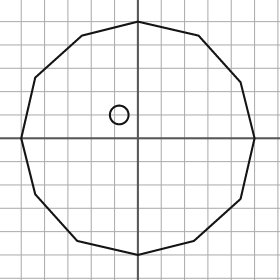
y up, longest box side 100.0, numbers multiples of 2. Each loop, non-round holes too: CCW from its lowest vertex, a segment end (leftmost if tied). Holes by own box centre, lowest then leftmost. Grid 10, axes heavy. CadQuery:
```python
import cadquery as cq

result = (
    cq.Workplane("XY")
    .moveTo(0.0, -50.0)
    .lineTo(24.0, -44.0)
    .lineTo(44.0, -26.0)
    .lineTo(50.0, 0.0)
    .lineTo(44.0, 24.0)
    .lineTo(26.0, 44.0)
    .lineTo(0.0, 50.0)
    .lineTo(-24.0, 44.0)
    .lineTo(-44.0, 26.0)
    .lineTo(-50.0, 0.0)
    .lineTo(-44.0, -24.0)
    .lineTo(-26.0, -44.0)
    .close()
    .moveTo(-8.0, 10.0)
    .circle(4.0)
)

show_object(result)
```